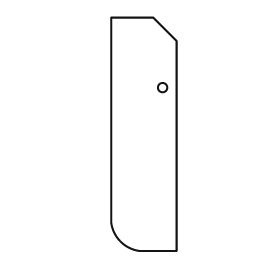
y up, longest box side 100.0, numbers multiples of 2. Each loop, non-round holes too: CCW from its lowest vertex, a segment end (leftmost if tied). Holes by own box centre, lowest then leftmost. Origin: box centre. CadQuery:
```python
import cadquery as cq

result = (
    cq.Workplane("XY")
    .moveTo(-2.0, -50.0)
    .lineTo(14.0, -50.0)
    .lineTo(14.0, 40.0)
    .lineTo(4.0, 50.0)
    .lineTo(-14.0, 50.0)
    .lineTo(-14.0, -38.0)
    .threePointArc((-10.0, -46.0), (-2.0, -50.0))
    .close()
    .moveTo(8.0, 20.0)
    .circle(2.0)
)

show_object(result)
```